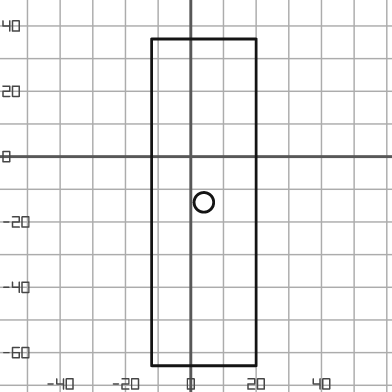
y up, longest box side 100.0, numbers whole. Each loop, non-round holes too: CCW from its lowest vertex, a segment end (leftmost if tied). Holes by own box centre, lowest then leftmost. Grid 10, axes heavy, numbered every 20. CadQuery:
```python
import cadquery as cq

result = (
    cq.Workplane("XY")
    .moveTo(-12.0, -64.0)
    .lineTo(20.0, -64.0)
    .lineTo(20.0, 36.0)
    .lineTo(-12.0, 36.0)
    .close()
    .moveTo(4.0, -14.0)
    .circle(3.0)
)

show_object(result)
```